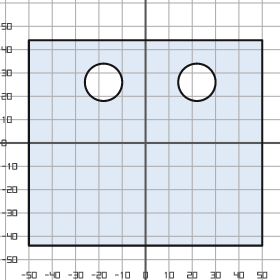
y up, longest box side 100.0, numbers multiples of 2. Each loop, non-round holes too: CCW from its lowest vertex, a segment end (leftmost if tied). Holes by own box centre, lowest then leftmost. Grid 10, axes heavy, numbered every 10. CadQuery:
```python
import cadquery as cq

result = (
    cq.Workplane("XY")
    .moveTo(-50.0, -44.0)
    .lineTo(50.0, -44.0)
    .lineTo(50.0, 44.0)
    .lineTo(-50.0, 44.0)
    .close()
    .moveTo(-18.0, 26.0)
    .circle(8.0)
    .moveTo(22.0, 26.0)
    .circle(8.0)
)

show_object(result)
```